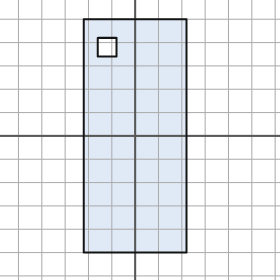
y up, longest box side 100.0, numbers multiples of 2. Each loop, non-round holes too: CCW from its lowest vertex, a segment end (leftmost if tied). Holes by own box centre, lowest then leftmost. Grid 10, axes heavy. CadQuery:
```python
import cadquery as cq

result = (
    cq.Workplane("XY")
    .moveTo(-22.0, -50.0)
    .lineTo(22.0, -50.0)
    .lineTo(22.0, 50.0)
    .lineTo(-22.0, 50.0)
    .close()
    .moveTo(-16.0, 34.0)
    .lineTo(-8.0, 34.0)
    .lineTo(-8.0, 42.0)
    .lineTo(-16.0, 42.0)
    .close()
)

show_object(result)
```